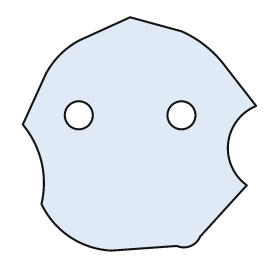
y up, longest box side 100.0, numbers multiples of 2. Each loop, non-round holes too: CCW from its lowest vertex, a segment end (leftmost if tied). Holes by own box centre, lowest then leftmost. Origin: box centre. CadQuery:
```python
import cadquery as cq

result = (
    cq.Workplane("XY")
    .moveTo(-12.0, -50.0)
    .lineTo(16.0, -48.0)
    .threePointArc((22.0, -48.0), (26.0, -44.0))
    .lineTo(46.0, -22.0)
    .threePointArc((38.0, -4.0), (50.0, 12.0))
    .lineTo(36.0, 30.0)
    .threePointArc((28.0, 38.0), (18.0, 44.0))
    .lineTo(-4.0, 50.0)
    .lineTo(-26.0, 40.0)
    .threePointArc((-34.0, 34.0), (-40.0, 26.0))
    .lineTo(-50.0, 4.0)
    .threePointArc((-42.0, -12.0), (-42.0, -30.0))
    .threePointArc((-30.0, -44.0), (-12.0, -50.0))
    .close()
    .moveTo(-26.0, 8.0)
    .circle(6.0)
    .moveTo(18.0, 8.0)
    .circle(6.0)
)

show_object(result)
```